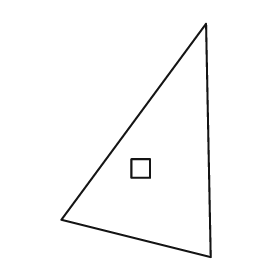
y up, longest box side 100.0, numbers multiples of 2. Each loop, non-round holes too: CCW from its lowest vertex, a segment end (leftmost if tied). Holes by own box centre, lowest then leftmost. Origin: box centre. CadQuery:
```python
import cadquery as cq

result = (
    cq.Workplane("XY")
    .moveTo(32.0, -50.0)
    .lineTo(30.0, 50.0)
    .lineTo(-32.0, -34.0)
    .close()
    .moveTo(-2.0, -16.0)
    .lineTo(6.0, -16.0)
    .lineTo(6.0, -8.0)
    .lineTo(-2.0, -8.0)
    .close()
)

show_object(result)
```